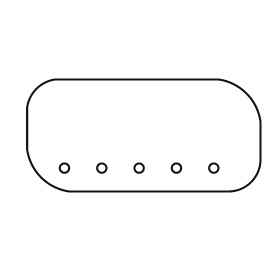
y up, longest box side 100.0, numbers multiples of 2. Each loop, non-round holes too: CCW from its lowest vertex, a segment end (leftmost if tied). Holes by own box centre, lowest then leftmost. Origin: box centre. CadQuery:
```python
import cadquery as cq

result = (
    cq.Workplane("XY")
    .moveTo(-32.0, -24.0)
    .lineTo(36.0, -24.0)
    .threePointArc((46.0, -20.0), (50.0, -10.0))
    .lineTo(50.0, 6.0)
    .threePointArc((44.0, 18.0), (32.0, 24.0))
    .lineTo(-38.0, 24.0)
    .threePointArc((-46.0, 20.0), (-50.0, 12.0))
    .lineTo(-50.0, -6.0)
    .threePointArc((-44.0, -18.0), (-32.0, -24.0))
    .close()
    .moveTo(-34.0, -14.0)
    .circle(2.0)
    .moveTo(-18.0, -14.0)
    .circle(2.0)
    .moveTo(-2.0, -14.0)
    .circle(2.0)
    .moveTo(14.0, -14.0)
    .circle(2.0)
    .moveTo(30.0, -14.0)
    .circle(2.0)
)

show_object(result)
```